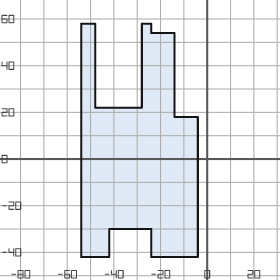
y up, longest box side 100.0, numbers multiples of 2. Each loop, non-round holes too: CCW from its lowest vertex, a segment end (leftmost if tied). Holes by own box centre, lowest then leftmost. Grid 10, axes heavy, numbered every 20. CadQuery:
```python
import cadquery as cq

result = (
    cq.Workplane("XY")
    .moveTo(-54.0, -42.0)
    .lineTo(-42.0, -42.0)
    .lineTo(-42.0, -30.0)
    .lineTo(-24.0, -30.0)
    .lineTo(-24.0, -42.0)
    .lineTo(-4.0, -42.0)
    .lineTo(-4.0, 18.0)
    .lineTo(-14.0, 18.0)
    .lineTo(-14.0, 54.0)
    .lineTo(-24.0, 54.0)
    .lineTo(-24.0, 58.0)
    .lineTo(-28.0, 58.0)
    .lineTo(-28.0, 22.0)
    .lineTo(-48.0, 22.0)
    .lineTo(-48.0, 58.0)
    .lineTo(-54.0, 58.0)
    .close()
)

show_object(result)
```